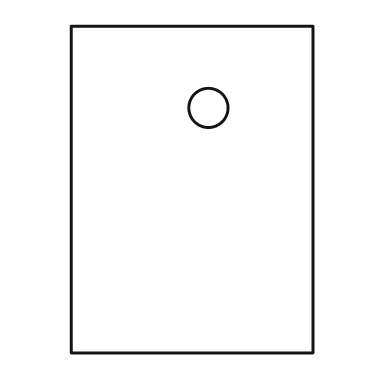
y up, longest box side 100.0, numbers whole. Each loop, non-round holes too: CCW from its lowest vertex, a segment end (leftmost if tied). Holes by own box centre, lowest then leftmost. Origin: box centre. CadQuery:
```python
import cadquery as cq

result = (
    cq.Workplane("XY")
    .moveTo(-37.0, -50.0)
    .lineTo(37.0, -50.0)
    .lineTo(37.0, 50.0)
    .lineTo(-37.0, 50.0)
    .close()
    .moveTo(5.0, 25.0)
    .circle(6.0)
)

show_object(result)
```